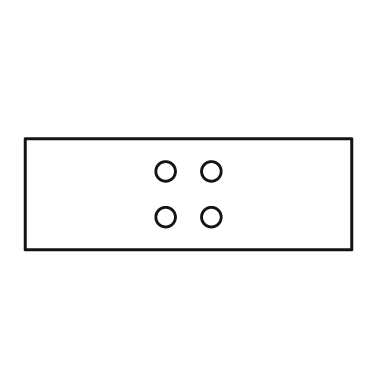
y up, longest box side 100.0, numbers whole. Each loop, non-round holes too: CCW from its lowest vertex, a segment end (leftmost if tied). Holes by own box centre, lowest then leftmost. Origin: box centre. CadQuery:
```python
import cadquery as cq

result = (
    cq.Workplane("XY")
    .moveTo(-50.0, -17.0)
    .lineTo(50.0, -17.0)
    .lineTo(50.0, 17.0)
    .lineTo(-50.0, 17.0)
    .close()
    .moveTo(-7.0, -7.0)
    .circle(3.0)
    .moveTo(7.0, -7.0)
    .circle(3.0)
    .moveTo(-7.0, 7.0)
    .circle(3.0)
    .moveTo(7.0, 7.0)
    .circle(3.0)
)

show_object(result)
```